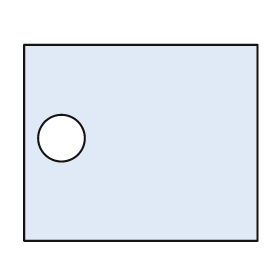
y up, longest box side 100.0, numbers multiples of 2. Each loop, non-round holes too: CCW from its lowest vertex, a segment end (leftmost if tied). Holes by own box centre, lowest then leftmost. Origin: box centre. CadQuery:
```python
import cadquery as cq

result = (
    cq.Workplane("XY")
    .moveTo(-50.0, -42.0)
    .lineTo(50.0, -42.0)
    .lineTo(50.0, 42.0)
    .lineTo(-50.0, 42.0)
    .close()
    .moveTo(-34.0, 2.0)
    .circle(10.0)
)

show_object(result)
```